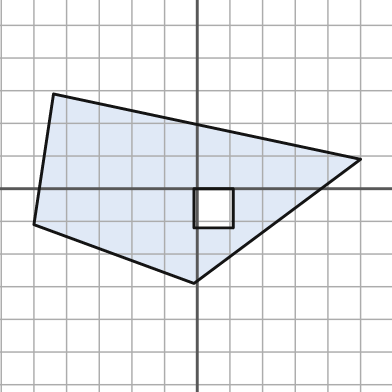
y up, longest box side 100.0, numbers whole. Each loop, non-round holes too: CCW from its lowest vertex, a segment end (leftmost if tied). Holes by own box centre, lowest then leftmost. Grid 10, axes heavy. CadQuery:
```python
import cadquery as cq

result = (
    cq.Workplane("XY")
    .moveTo(-1.0, -29.0)
    .lineTo(50.0, 9.0)
    .lineTo(-44.0, 29.0)
    .lineTo(-50.0, -11.0)
    .close()
    .moveTo(-1.0, -12.0)
    .lineTo(11.0, -12.0)
    .lineTo(11.0, 0.0)
    .lineTo(-1.0, 0.0)
    .close()
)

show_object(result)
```